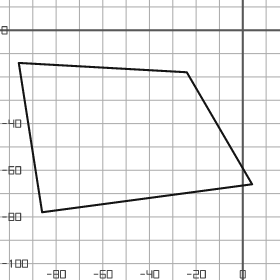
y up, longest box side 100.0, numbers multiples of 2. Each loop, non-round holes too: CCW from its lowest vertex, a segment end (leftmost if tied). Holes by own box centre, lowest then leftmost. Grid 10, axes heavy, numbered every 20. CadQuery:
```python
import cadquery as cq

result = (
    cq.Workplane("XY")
    .moveTo(-86.0, -78.0)
    .lineTo(4.0, -66.0)
    .lineTo(-24.0, -18.0)
    .lineTo(-96.0, -14.0)
    .close()
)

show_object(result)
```